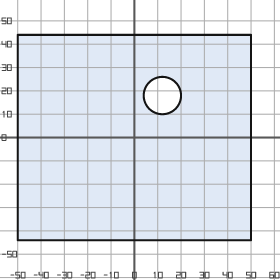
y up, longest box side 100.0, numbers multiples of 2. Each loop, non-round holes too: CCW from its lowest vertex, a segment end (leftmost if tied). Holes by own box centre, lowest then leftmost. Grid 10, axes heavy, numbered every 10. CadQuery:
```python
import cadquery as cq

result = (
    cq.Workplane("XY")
    .moveTo(-50.0, -44.0)
    .lineTo(50.0, -44.0)
    .lineTo(50.0, 44.0)
    .lineTo(-50.0, 44.0)
    .close()
    .moveTo(12.0, 18.0)
    .circle(8.0)
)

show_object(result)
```